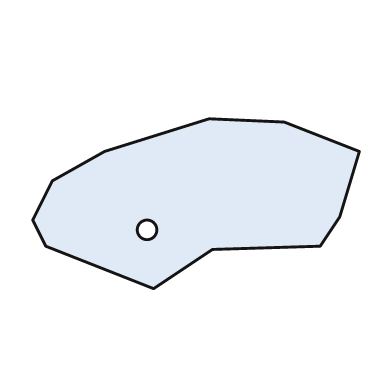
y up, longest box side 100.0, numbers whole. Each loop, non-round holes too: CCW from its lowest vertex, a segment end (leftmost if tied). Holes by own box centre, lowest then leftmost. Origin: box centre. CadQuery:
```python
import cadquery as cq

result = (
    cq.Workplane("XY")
    .moveTo(-13.0, -26.0)
    .lineTo(5.0, -14.0)
    .lineTo(38.0, -13.0)
    .lineTo(44.0, -4.0)
    .lineTo(50.0, 16.0)
    .lineTo(27.0, 25.0)
    .lineTo(4.0, 26.0)
    .lineTo(-28.0, 16.0)
    .lineTo(-44.0, 7.0)
    .lineTo(-50.0, -5.0)
    .lineTo(-46.0, -13.0)
    .close()
    .moveTo(-15.0, -8.0)
    .circle(3.0)
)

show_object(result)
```